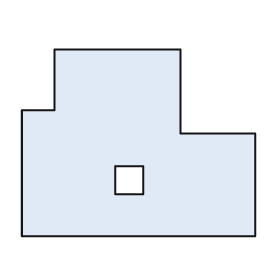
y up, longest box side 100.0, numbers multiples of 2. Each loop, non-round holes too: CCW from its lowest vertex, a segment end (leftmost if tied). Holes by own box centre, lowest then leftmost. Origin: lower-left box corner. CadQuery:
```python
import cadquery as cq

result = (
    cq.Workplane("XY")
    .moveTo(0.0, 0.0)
    .lineTo(100.0, 0.0)
    .lineTo(100.0, 44.0)
    .lineTo(68.0, 44.0)
    .lineTo(68.0, 80.0)
    .lineTo(14.0, 80.0)
    .lineTo(14.0, 54.0)
    .lineTo(0.0, 54.0)
    .close()
    .moveTo(40.0, 18.0)
    .lineTo(52.0, 18.0)
    .lineTo(52.0, 30.0)
    .lineTo(40.0, 30.0)
    .close()
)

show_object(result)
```